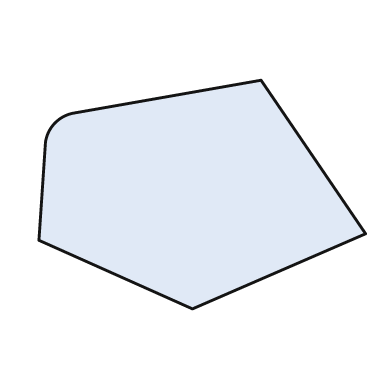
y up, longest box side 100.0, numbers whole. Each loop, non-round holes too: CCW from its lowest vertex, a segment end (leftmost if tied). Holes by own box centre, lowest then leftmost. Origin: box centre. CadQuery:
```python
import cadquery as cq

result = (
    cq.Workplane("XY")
    .moveTo(-3.0, -35.0)
    .lineTo(50.0, -12.0)
    .lineTo(18.0, 35.0)
    .lineTo(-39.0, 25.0)
    .threePointArc((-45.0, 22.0), (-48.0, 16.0))
    .lineTo(-50.0, -14.0)
    .close()
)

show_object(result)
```